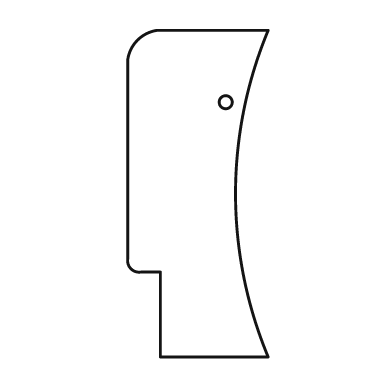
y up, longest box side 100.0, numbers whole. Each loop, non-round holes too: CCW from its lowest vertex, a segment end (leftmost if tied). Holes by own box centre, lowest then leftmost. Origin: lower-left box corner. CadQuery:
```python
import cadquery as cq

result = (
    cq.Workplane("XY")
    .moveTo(10.0, 0.0)
    .lineTo(43.0, 0.0)
    .threePointArc((33.0, 50.0), (43.0, 100.0))
    .lineTo(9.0, 100.0)
    .threePointArc((3.0, 97.0), (0.0, 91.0))
    .lineTo(0.0, 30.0)
    .threePointArc((1.0, 27.0), (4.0, 26.0))
    .lineTo(10.0, 26.0)
    .close()
    .moveTo(30.0, 78.0)
    .circle(2.0)
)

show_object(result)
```